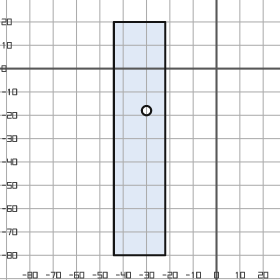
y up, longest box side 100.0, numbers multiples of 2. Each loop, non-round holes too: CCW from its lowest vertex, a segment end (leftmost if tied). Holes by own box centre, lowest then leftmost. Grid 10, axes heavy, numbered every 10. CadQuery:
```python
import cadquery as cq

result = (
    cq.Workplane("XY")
    .moveTo(-44.0, -80.0)
    .lineTo(-22.0, -80.0)
    .lineTo(-22.0, 20.0)
    .lineTo(-44.0, 20.0)
    .close()
    .moveTo(-30.0, -18.0)
    .circle(2.0)
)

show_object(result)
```